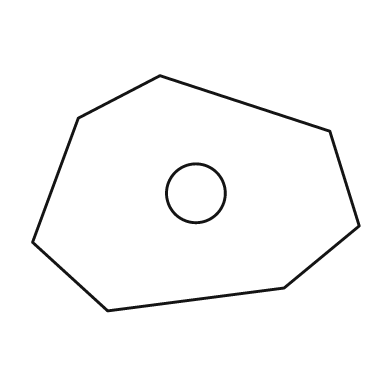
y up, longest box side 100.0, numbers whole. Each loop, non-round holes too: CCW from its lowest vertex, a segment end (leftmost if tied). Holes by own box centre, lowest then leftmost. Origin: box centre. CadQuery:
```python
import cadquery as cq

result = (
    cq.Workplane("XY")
    .moveTo(-27.0, -36.0)
    .lineTo(27.0, -29.0)
    .lineTo(50.0, -10.0)
    .lineTo(41.0, 19.0)
    .lineTo(-11.0, 36.0)
    .lineTo(-36.0, 23.0)
    .lineTo(-50.0, -15.0)
    .close()
    .moveTo(0.0, 0.0)
    .circle(9.0)
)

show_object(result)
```